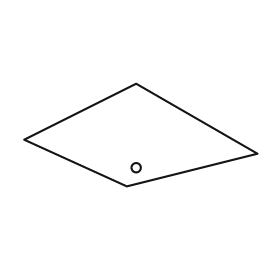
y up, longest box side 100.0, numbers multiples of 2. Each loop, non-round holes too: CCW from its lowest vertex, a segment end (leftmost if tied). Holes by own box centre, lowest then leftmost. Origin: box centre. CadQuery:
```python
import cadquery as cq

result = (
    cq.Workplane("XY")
    .moveTo(-6.0, -22.0)
    .lineTo(50.0, -8.0)
    .lineTo(-2.0, 22.0)
    .lineTo(-50.0, -2.0)
    .close()
    .moveTo(-2.0, -14.0)
    .circle(2.0)
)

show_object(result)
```